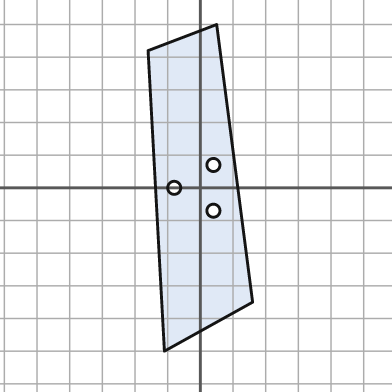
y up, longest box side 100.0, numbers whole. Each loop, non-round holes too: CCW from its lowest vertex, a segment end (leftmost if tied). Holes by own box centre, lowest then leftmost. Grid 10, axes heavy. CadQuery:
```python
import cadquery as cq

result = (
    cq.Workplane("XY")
    .moveTo(-11.0, -50.0)
    .lineTo(16.0, -35.0)
    .lineTo(5.0, 50.0)
    .lineTo(-16.0, 42.0)
    .close()
    .moveTo(4.0, -7.0)
    .circle(2.0)
    .moveTo(-8.0, 0.0)
    .circle(2.0)
    .moveTo(4.0, 7.0)
    .circle(2.0)
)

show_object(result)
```